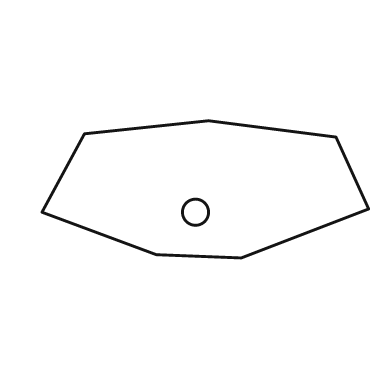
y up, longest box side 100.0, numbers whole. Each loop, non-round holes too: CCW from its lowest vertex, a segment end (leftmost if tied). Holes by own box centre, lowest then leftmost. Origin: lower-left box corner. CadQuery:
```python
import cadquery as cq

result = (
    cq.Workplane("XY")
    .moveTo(61.0, 0.0)
    .lineTo(100.0, 15.0)
    .lineTo(90.0, 37.0)
    .lineTo(51.0, 42.0)
    .lineTo(13.0, 38.0)
    .lineTo(0.0, 14.0)
    .lineTo(35.0, 1.0)
    .close()
    .moveTo(47.0, 14.0)
    .circle(4.0)
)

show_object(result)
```